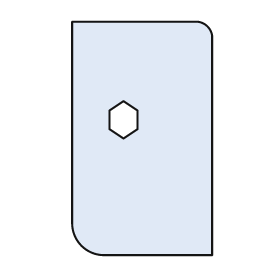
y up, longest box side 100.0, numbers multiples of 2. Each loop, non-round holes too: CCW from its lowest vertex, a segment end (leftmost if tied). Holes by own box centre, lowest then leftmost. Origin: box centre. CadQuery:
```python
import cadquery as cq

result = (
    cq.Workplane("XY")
    .moveTo(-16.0, -50.0)
    .lineTo(30.0, -50.0)
    .lineTo(30.0, 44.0)
    .threePointArc((28.0, 48.0), (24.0, 50.0))
    .lineTo(-30.0, 50.0)
    .lineTo(-30.0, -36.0)
    .threePointArc((-26.0, -46.0), (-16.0, -50.0))
    .close()
    .moveTo(-8.0, 0.0)
    .lineTo(-2.0, 4.0)
    .lineTo(-2.0, 12.0)
    .lineTo(-8.0, 16.0)
    .lineTo(-14.0, 12.0)
    .lineTo(-14.0, 4.0)
    .close()
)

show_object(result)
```